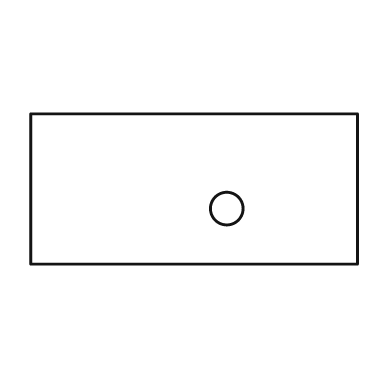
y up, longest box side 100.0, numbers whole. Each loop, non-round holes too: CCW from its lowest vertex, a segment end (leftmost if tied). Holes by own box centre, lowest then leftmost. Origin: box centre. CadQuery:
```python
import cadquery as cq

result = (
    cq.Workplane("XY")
    .moveTo(-50.0, -23.0)
    .lineTo(50.0, -23.0)
    .lineTo(50.0, 23.0)
    .lineTo(-50.0, 23.0)
    .close()
    .moveTo(10.0, -6.0)
    .circle(5.0)
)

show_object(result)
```